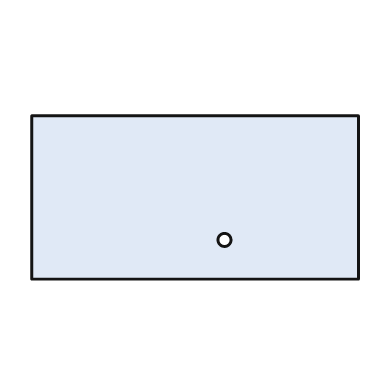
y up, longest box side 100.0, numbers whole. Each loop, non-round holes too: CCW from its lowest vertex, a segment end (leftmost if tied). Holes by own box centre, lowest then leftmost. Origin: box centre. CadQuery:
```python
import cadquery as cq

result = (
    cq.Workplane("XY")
    .moveTo(-50.0, -25.0)
    .lineTo(50.0, -25.0)
    .lineTo(50.0, 25.0)
    .lineTo(-50.0, 25.0)
    .close()
    .moveTo(9.0, -13.0)
    .circle(2.0)
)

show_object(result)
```